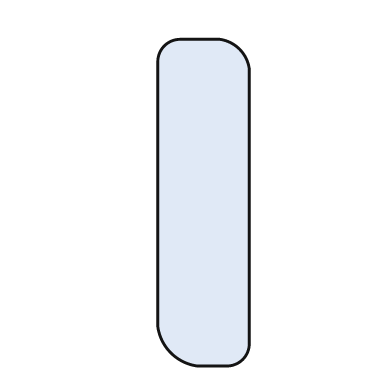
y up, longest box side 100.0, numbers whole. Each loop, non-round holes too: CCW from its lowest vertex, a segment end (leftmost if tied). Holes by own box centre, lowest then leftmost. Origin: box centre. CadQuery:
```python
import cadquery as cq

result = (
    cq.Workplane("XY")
    .moveTo(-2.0, -50.0)
    .lineTo(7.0, -50.0)
    .threePointArc((12.0, -48.0), (14.0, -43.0))
    .lineTo(14.0, 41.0)
    .threePointArc((11.0, 47.0), (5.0, 50.0))
    .lineTo(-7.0, 50.0)
    .threePointArc((-12.0, 48.0), (-14.0, 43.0))
    .lineTo(-14.0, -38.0)
    .threePointArc((-10.0, -46.0), (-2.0, -50.0))
    .close()
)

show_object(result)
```